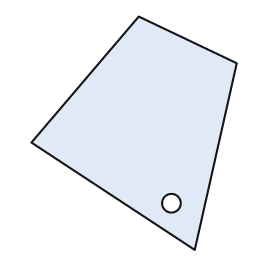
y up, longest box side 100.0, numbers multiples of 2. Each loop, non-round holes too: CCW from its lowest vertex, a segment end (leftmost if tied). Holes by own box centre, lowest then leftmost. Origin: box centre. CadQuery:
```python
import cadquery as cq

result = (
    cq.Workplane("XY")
    .moveTo(26.0, -50.0)
    .lineTo(44.0, 30.0)
    .lineTo(2.0, 50.0)
    .lineTo(-44.0, -4.0)
    .close()
    .moveTo(16.0, -30.0)
    .circle(4.0)
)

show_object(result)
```